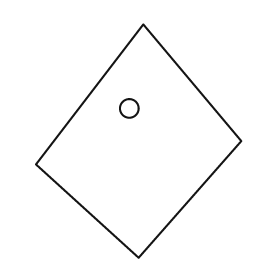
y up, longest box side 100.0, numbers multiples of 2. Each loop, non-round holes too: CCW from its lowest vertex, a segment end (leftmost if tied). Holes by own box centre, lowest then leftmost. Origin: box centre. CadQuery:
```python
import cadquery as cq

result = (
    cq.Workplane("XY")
    .moveTo(0.0, -50.0)
    .lineTo(44.0, 0.0)
    .lineTo(2.0, 50.0)
    .lineTo(-44.0, -10.0)
    .close()
    .moveTo(-4.0, 14.0)
    .circle(4.0)
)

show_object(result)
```